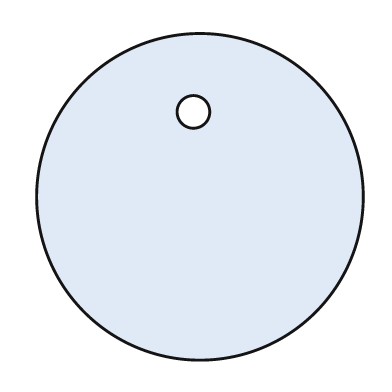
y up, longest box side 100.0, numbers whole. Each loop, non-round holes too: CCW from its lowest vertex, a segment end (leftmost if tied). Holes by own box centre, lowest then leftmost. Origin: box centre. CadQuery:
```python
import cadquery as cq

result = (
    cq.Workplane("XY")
    .moveTo(0.0, 0.0)
    .circle(50.0)
    .moveTo(-2.0, 26.0)
    .circle(5.0)
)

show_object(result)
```